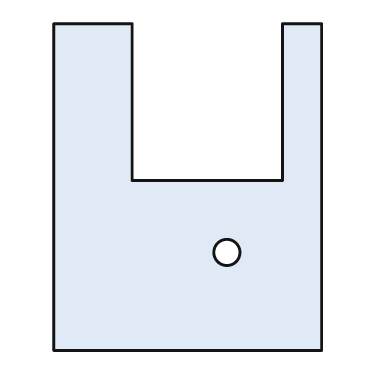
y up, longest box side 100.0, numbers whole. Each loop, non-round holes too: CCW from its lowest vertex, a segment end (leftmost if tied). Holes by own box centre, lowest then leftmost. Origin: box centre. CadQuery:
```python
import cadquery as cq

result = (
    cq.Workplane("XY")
    .moveTo(-41.0, -50.0)
    .lineTo(41.0, -50.0)
    .lineTo(41.0, 50.0)
    .lineTo(29.0, 50.0)
    .lineTo(29.0, 2.0)
    .lineTo(-17.0, 2.0)
    .lineTo(-17.0, 50.0)
    .lineTo(-41.0, 50.0)
    .close()
    .moveTo(12.0, -20.0)
    .circle(4.0)
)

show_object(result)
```